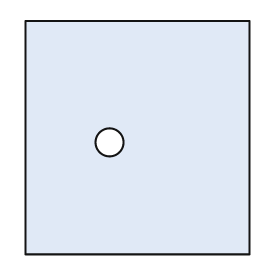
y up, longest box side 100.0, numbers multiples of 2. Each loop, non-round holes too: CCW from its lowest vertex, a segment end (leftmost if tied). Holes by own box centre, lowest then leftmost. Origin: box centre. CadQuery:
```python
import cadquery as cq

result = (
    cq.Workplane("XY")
    .moveTo(-48.0, -50.0)
    .lineTo(48.0, -50.0)
    .lineTo(48.0, 50.0)
    .lineTo(-48.0, 50.0)
    .close()
    .moveTo(-12.0, -2.0)
    .circle(6.0)
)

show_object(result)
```